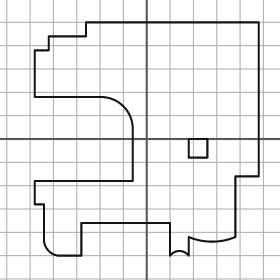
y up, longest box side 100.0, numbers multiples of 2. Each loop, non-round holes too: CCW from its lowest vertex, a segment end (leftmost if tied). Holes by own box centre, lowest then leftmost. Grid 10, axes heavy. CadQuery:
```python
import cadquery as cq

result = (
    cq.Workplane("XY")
    .moveTo(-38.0, -50.0)
    .lineTo(-28.0, -50.0)
    .lineTo(-28.0, -36.0)
    .lineTo(10.0, -36.0)
    .lineTo(10.0, -50.0)
    .threePointArc((14.0, -48.0), (18.0, -50.0))
    .lineTo(18.0, -42.0)
    .threePointArc((28.0, -44.0), (38.0, -42.0))
    .lineTo(38.0, -16.0)
    .lineTo(48.0, -16.0)
    .lineTo(48.0, 50.0)
    .lineTo(-26.0, 50.0)
    .lineTo(-26.0, 44.0)
    .lineTo(-42.0, 44.0)
    .lineTo(-42.0, 38.0)
    .lineTo(-48.0, 38.0)
    .lineTo(-48.0, 18.0)
    .lineTo(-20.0, 18.0)
    .threePointArc((-10.0, 14.0), (-6.0, 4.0))
    .lineTo(-6.0, -18.0)
    .lineTo(-48.0, -18.0)
    .lineTo(-48.0, -28.0)
    .lineTo(-44.0, -28.0)
    .lineTo(-44.0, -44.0)
    .threePointArc((-42.0, -48.0), (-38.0, -50.0))
    .close()
    .moveTo(18.0, -8.0)
    .lineTo(26.0, -8.0)
    .lineTo(26.0, 0.0)
    .lineTo(18.0, 0.0)
    .close()
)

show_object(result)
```